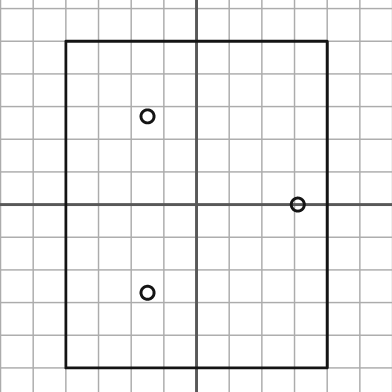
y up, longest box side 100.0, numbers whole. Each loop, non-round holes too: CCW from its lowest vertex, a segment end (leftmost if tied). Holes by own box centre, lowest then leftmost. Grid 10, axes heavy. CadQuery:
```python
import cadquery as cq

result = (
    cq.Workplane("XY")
    .moveTo(-40.0, -50.0)
    .lineTo(40.0, -50.0)
    .lineTo(40.0, 50.0)
    .lineTo(-40.0, 50.0)
    .close()
    .moveTo(-15.0, -27.0)
    .circle(2.0)
    .moveTo(31.0, 0.0)
    .circle(2.0)
    .moveTo(-15.0, 27.0)
    .circle(2.0)
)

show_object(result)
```